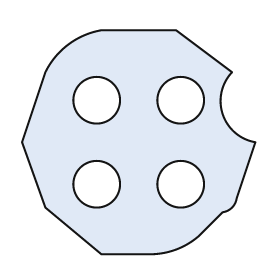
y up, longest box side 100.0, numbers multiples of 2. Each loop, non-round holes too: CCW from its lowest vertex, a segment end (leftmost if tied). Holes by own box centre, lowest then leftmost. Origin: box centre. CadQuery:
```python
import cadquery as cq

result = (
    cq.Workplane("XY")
    .moveTo(-16.0, -48.0)
    .lineTo(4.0, -48.0)
    .threePointArc((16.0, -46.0), (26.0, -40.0))
    .lineTo(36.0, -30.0)
    .threePointArc((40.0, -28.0), (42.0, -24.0))
    .lineTo(50.0, 0.0)
    .threePointArc((36.0, 12.0), (40.0, 30.0))
    .lineTo(16.0, 48.0)
    .lineTo(-16.0, 48.0)
    .threePointArc((-30.0, 42.0), (-40.0, 30.0))
    .lineTo(-50.0, 0.0)
    .lineTo(-40.0, -28.0)
    .close()
    .moveTo(-18.0, -18.0)
    .circle(10.0)
    .moveTo(18.0, -18.0)
    .circle(10.0)
    .moveTo(-18.0, 18.0)
    .circle(10.0)
    .moveTo(18.0, 18.0)
    .circle(10.0)
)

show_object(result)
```